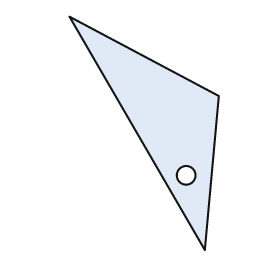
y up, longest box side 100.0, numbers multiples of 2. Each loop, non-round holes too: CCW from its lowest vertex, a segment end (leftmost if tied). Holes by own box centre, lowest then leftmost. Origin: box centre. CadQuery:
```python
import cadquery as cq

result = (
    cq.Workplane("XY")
    .moveTo(26.0, -50.0)
    .lineTo(32.0, 16.0)
    .lineTo(-32.0, 50.0)
    .close()
    .moveTo(18.0, -18.0)
    .circle(4.0)
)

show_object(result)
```